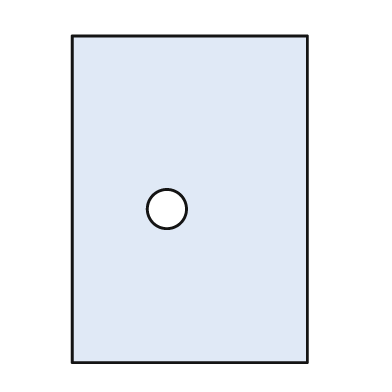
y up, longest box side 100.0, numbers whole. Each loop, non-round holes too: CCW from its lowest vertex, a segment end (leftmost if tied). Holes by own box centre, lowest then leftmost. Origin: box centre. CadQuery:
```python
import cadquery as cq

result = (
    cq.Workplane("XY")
    .moveTo(-36.0, -50.0)
    .lineTo(36.0, -50.0)
    .lineTo(36.0, 50.0)
    .lineTo(-36.0, 50.0)
    .close()
    .moveTo(-7.0, -3.0)
    .circle(6.0)
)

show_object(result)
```